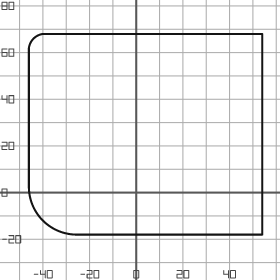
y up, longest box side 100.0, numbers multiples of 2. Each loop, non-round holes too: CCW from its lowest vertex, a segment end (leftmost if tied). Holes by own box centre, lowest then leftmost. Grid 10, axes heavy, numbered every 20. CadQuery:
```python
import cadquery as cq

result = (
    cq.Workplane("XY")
    .moveTo(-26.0, -18.0)
    .lineTo(54.0, -18.0)
    .lineTo(54.0, 68.0)
    .lineTo(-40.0, 68.0)
    .threePointArc((-44.0, 66.0), (-46.0, 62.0))
    .lineTo(-46.0, 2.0)
    .threePointArc((-40.0, -12.0), (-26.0, -18.0))
    .close()
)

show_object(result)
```